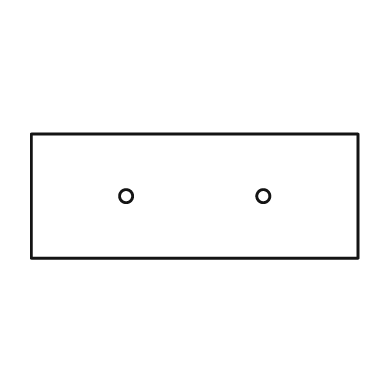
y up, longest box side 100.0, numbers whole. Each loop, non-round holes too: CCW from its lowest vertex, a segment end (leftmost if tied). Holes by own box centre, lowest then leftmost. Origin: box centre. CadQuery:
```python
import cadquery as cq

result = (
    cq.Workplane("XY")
    .moveTo(-50.0, -19.0)
    .lineTo(50.0, -19.0)
    .lineTo(50.0, 19.0)
    .lineTo(-50.0, 19.0)
    .close()
    .moveTo(-21.0, 0.0)
    .circle(2.0)
    .moveTo(21.0, 0.0)
    .circle(2.0)
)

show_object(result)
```